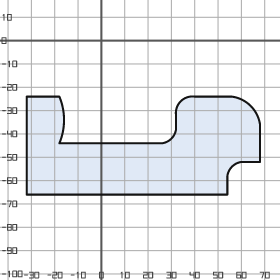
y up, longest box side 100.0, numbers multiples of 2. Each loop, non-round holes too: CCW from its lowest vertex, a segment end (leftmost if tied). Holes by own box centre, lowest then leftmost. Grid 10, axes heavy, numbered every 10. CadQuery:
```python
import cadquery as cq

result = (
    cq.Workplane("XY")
    .moveTo(-32.0, -66.0)
    .lineTo(54.0, -66.0)
    .lineTo(54.0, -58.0)
    .threePointArc((56.0, -54.0), (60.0, -52.0))
    .lineTo(68.0, -52.0)
    .lineTo(68.0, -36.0)
    .threePointArc((64.0, -28.0), (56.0, -24.0))
    .lineTo(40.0, -24.0)
    .threePointArc((34.0, -26.0), (32.0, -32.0))
    .lineTo(32.0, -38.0)
    .threePointArc((30.0, -42.0), (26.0, -44.0))
    .lineTo(-18.0, -44.0)
    .threePointArc((-16.0, -34.0), (-18.0, -24.0))
    .lineTo(-32.0, -24.0)
    .close()
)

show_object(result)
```